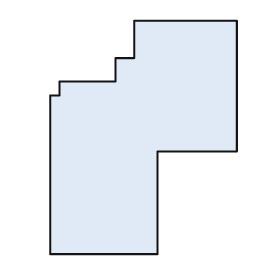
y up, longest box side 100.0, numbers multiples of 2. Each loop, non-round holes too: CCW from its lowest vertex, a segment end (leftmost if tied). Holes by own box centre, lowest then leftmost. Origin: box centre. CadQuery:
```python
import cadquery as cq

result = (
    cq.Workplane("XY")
    .moveTo(-40.0, -50.0)
    .lineTo(6.0, -50.0)
    .lineTo(6.0, -6.0)
    .lineTo(40.0, -6.0)
    .lineTo(40.0, 50.0)
    .lineTo(-4.0, 50.0)
    .lineTo(-4.0, 34.0)
    .lineTo(-12.0, 34.0)
    .lineTo(-12.0, 24.0)
    .lineTo(-36.0, 24.0)
    .lineTo(-36.0, 18.0)
    .lineTo(-40.0, 18.0)
    .close()
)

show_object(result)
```